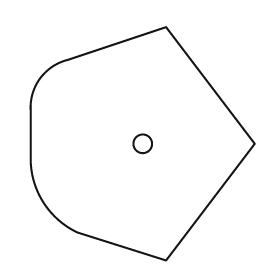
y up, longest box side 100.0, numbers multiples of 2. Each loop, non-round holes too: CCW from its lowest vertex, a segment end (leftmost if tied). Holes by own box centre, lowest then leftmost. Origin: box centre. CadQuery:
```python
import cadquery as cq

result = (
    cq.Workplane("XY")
    .moveTo(10.0, -50.0)
    .lineTo(48.0, 0.0)
    .lineTo(10.0, 50.0)
    .lineTo(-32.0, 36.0)
    .threePointArc((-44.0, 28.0), (-48.0, 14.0))
    .lineTo(-48.0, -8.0)
    .threePointArc((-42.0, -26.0), (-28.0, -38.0))
    .close()
    .moveTo(0.0, 0.0)
    .circle(4.0)
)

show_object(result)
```